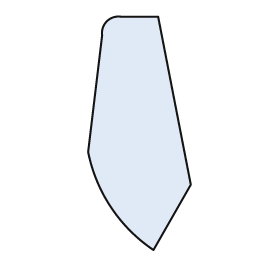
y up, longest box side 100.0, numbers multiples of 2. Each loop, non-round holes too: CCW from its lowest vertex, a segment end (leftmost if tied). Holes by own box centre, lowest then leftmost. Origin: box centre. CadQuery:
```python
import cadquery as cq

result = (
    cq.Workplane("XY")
    .moveTo(6.0, -50.0)
    .lineTo(22.0, -22.0)
    .lineTo(8.0, 50.0)
    .lineTo(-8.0, 50.0)
    .threePointArc((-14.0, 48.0), (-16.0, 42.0))
    .lineTo(-22.0, -8.0)
    .threePointArc((-12.0, -32.0), (6.0, -50.0))
    .close()
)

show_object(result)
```